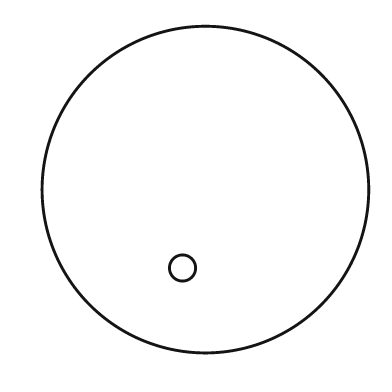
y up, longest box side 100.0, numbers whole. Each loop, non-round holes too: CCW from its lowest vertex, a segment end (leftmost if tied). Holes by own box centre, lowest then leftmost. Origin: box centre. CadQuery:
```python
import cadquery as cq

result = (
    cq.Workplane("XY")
    .moveTo(0.0, 0.0)
    .circle(50.0)
    .moveTo(-7.0, -24.0)
    .circle(4.0)
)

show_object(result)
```